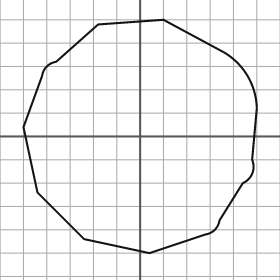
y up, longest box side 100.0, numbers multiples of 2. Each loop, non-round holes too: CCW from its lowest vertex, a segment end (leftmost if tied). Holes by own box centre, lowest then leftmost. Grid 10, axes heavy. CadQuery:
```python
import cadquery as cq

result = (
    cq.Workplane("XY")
    .moveTo(4.0, -50.0)
    .lineTo(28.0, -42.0)
    .threePointArc((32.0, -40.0), (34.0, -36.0))
    .lineTo(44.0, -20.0)
    .threePointArc((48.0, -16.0), (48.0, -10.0))
    .lineTo(50.0, 12.0)
    .threePointArc((46.0, 26.0), (36.0, 36.0))
    .lineTo(10.0, 50.0)
    .lineTo(-18.0, 48.0)
    .lineTo(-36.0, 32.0)
    .threePointArc((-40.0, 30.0), (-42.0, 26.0))
    .lineTo(-50.0, 4.0)
    .lineTo(-44.0, -24.0)
    .lineTo(-24.0, -44.0)
    .close()
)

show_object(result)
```